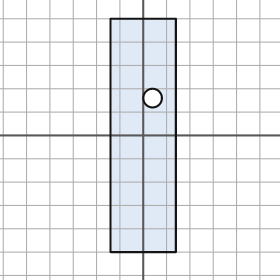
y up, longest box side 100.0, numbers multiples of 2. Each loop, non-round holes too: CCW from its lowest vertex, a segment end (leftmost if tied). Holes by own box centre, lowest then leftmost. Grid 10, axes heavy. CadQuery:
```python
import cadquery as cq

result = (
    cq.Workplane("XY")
    .moveTo(-14.0, -50.0)
    .lineTo(14.0, -50.0)
    .lineTo(14.0, 50.0)
    .lineTo(-14.0, 50.0)
    .close()
    .moveTo(4.0, 16.0)
    .circle(4.0)
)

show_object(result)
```